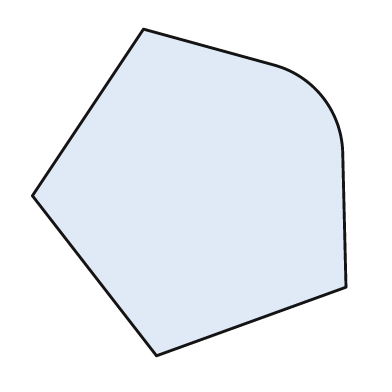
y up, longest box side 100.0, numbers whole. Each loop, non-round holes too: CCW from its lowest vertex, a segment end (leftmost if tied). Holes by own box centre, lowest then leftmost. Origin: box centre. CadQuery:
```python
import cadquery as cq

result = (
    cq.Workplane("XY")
    .moveTo(-10.0, -50.0)
    .lineTo(48.0, -29.0)
    .lineTo(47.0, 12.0)
    .threePointArc((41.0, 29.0), (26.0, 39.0))
    .lineTo(-14.0, 50.0)
    .lineTo(-48.0, -1.0)
    .close()
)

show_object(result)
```